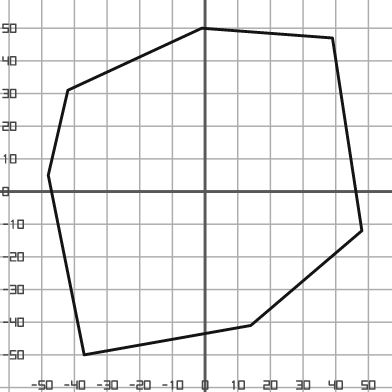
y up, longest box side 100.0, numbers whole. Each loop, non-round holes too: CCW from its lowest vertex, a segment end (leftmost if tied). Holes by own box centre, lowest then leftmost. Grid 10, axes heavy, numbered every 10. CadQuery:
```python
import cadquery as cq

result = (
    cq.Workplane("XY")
    .moveTo(-37.0, -50.0)
    .lineTo(14.0, -41.0)
    .lineTo(48.0, -12.0)
    .lineTo(39.0, 47.0)
    .lineTo(-1.0, 50.0)
    .lineTo(-42.0, 31.0)
    .lineTo(-48.0, 5.0)
    .close()
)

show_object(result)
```